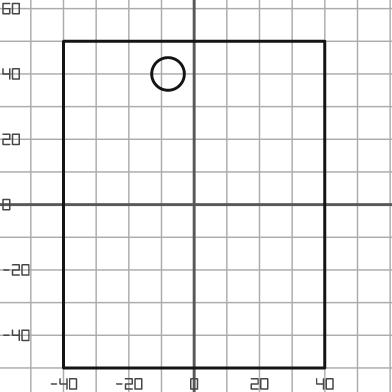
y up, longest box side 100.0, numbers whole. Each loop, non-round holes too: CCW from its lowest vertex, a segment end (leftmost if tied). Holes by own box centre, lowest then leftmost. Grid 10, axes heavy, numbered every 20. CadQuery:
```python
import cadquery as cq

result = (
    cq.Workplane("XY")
    .moveTo(-40.0, -50.0)
    .lineTo(40.0, -50.0)
    .lineTo(40.0, 50.0)
    .lineTo(-40.0, 50.0)
    .close()
    .moveTo(-8.0, 40.0)
    .circle(5.0)
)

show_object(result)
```